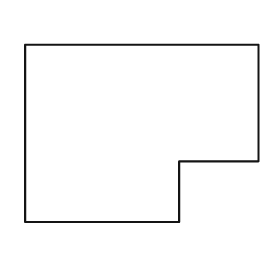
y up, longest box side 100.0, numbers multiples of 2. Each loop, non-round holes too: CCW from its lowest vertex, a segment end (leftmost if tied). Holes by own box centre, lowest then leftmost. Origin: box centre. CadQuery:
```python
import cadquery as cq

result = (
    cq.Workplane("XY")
    .moveTo(-50.0, -38.0)
    .lineTo(16.0, -38.0)
    .lineTo(16.0, -12.0)
    .lineTo(50.0, -12.0)
    .lineTo(50.0, 38.0)
    .lineTo(-50.0, 38.0)
    .close()
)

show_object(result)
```